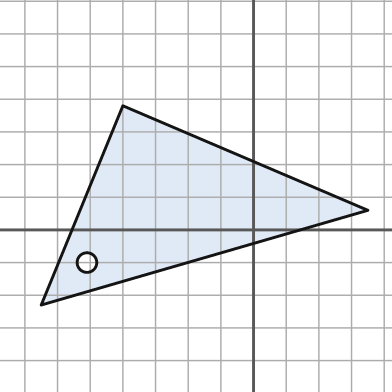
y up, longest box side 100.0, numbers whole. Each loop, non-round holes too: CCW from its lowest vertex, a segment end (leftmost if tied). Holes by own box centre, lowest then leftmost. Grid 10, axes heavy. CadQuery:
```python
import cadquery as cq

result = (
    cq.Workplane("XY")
    .moveTo(-65.0, -23.0)
    .lineTo(35.0, 6.0)
    .lineTo(-40.0, 38.0)
    .close()
    .moveTo(-51.0, -10.0)
    .circle(3.0)
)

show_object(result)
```